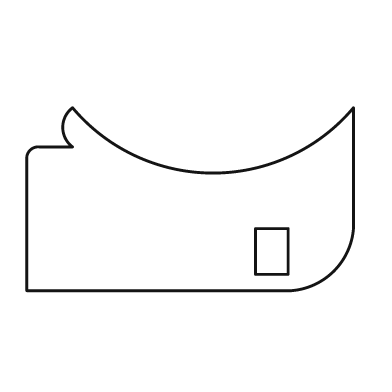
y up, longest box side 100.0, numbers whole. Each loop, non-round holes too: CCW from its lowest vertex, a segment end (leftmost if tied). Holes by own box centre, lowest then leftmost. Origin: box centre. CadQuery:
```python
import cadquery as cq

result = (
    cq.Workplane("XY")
    .moveTo(-50.0, -28.0)
    .lineTo(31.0, -28.0)
    .threePointArc((44.0, -22.0), (50.0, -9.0))
    .lineTo(50.0, 28.0)
    .threePointArc((7.0, 8.0), (-36.0, 28.0))
    .threePointArc((-39.0, 22.0), (-36.0, 16.0))
    .lineTo(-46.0, 16.0)
    .threePointArc((-49.0, 15.0), (-50.0, 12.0))
    .close()
    .moveTo(20.0, -23.0)
    .lineTo(30.0, -23.0)
    .lineTo(30.0, -9.0)
    .lineTo(20.0, -9.0)
    .close()
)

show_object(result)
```